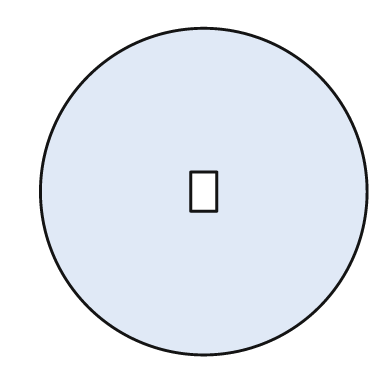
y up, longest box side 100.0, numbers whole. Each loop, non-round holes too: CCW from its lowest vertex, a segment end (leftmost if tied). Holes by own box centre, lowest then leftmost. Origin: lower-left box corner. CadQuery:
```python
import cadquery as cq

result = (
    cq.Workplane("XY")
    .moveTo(50.0, 50.0)
    .circle(50.0)
    .moveTo(46.0, 44.0)
    .lineTo(54.0, 44.0)
    .lineTo(54.0, 56.0)
    .lineTo(46.0, 56.0)
    .close()
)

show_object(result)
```